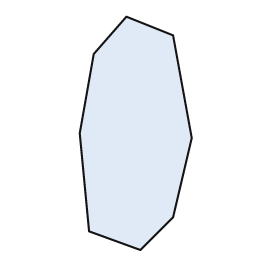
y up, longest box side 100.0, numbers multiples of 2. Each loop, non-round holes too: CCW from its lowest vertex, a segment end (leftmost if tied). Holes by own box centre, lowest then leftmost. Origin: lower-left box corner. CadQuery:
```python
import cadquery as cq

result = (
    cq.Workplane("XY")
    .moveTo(26.0, 0.0)
    .lineTo(40.0, 14.0)
    .lineTo(48.0, 48.0)
    .lineTo(40.0, 92.0)
    .lineTo(20.0, 100.0)
    .lineTo(6.0, 84.0)
    .lineTo(0.0, 50.0)
    .lineTo(4.0, 8.0)
    .close()
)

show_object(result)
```